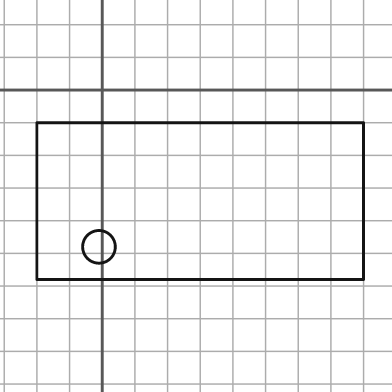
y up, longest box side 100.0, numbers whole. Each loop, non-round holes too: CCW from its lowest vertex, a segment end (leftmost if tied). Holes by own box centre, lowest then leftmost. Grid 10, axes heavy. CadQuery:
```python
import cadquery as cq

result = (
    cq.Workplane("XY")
    .moveTo(-20.0, -58.0)
    .lineTo(80.0, -58.0)
    .lineTo(80.0, -10.0)
    .lineTo(-20.0, -10.0)
    .close()
    .moveTo(-1.0, -48.0)
    .circle(5.0)
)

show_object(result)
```